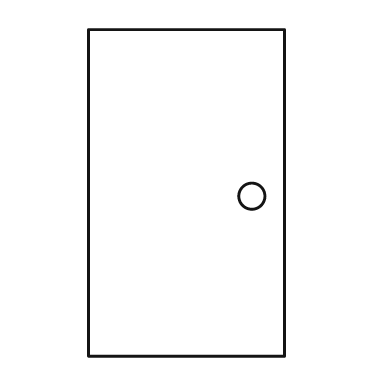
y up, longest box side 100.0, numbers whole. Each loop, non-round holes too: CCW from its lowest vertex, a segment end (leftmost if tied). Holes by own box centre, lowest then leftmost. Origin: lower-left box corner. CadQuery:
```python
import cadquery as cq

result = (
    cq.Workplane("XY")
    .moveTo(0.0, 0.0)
    .lineTo(60.0, 0.0)
    .lineTo(60.0, 100.0)
    .lineTo(0.0, 100.0)
    .close()
    .moveTo(50.0, 49.0)
    .circle(4.0)
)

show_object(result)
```